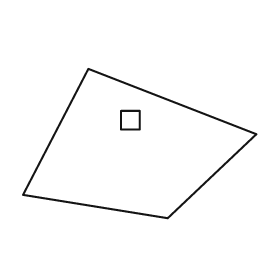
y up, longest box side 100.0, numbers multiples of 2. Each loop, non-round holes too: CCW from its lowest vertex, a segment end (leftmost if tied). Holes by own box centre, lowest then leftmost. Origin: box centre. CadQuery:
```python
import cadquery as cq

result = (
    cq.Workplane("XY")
    .moveTo(12.0, -32.0)
    .lineTo(50.0, 4.0)
    .lineTo(-22.0, 32.0)
    .lineTo(-50.0, -22.0)
    .close()
    .moveTo(-8.0, 6.0)
    .lineTo(0.0, 6.0)
    .lineTo(0.0, 14.0)
    .lineTo(-8.0, 14.0)
    .close()
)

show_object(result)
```